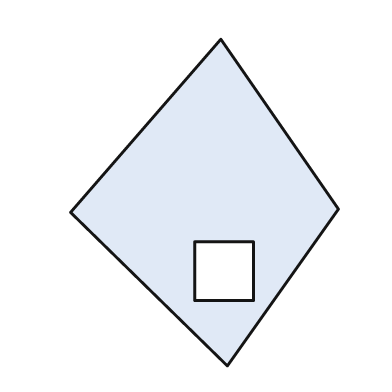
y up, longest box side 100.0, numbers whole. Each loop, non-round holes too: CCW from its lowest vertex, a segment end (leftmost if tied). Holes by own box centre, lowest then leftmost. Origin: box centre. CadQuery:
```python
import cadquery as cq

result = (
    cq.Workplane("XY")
    .moveTo(7.0, -50.0)
    .lineTo(41.0, -2.0)
    .lineTo(5.0, 50.0)
    .lineTo(-41.0, -3.0)
    .close()
    .moveTo(-3.0, -30.0)
    .lineTo(15.0, -30.0)
    .lineTo(15.0, -12.0)
    .lineTo(-3.0, -12.0)
    .close()
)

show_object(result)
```